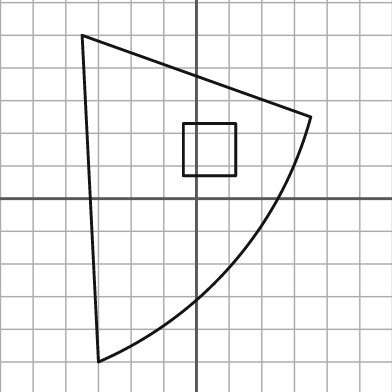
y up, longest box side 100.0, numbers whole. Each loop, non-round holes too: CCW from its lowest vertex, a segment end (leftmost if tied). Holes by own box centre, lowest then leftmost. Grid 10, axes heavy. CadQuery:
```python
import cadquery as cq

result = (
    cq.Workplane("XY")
    .moveTo(-30.0, -50.0)
    .threePointArc((11.0, -20.0), (35.0, 25.0))
    .lineTo(-35.0, 50.0)
    .close()
    .moveTo(-4.0, 7.0)
    .lineTo(12.0, 7.0)
    .lineTo(12.0, 23.0)
    .lineTo(-4.0, 23.0)
    .close()
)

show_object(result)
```